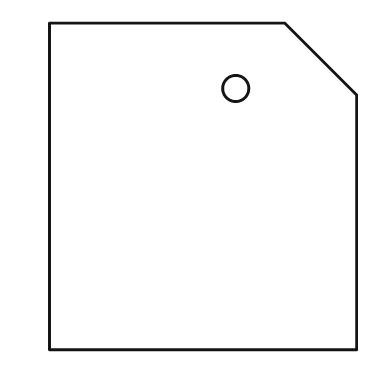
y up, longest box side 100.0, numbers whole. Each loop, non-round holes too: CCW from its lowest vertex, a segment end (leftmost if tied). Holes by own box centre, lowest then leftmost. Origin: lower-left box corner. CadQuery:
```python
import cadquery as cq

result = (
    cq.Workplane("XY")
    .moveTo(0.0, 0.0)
    .lineTo(94.0, 0.0)
    .lineTo(94.0, 78.0)
    .lineTo(72.0, 100.0)
    .lineTo(0.0, 100.0)
    .close()
    .moveTo(57.0, 80.0)
    .circle(4.0)
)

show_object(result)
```